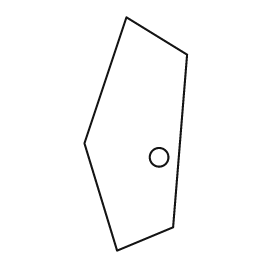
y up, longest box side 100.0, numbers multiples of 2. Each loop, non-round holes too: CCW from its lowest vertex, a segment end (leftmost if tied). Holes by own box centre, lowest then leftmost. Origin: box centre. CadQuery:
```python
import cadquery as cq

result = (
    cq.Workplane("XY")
    .moveTo(-8.0, -50.0)
    .lineTo(16.0, -40.0)
    .lineTo(22.0, 34.0)
    .lineTo(-4.0, 50.0)
    .lineTo(-22.0, -4.0)
    .close()
    .moveTo(10.0, -10.0)
    .circle(4.0)
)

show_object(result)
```